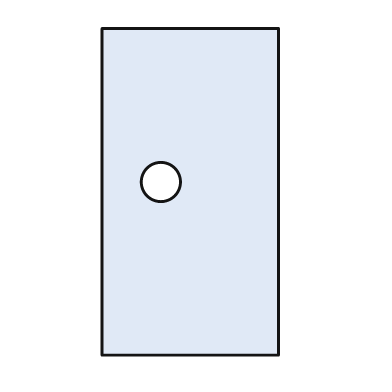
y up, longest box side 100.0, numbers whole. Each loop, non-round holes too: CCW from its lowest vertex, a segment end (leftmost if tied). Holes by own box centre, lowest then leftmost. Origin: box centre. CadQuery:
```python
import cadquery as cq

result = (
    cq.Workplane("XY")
    .moveTo(-27.0, -50.0)
    .lineTo(27.0, -50.0)
    .lineTo(27.0, 50.0)
    .lineTo(-27.0, 50.0)
    .close()
    .moveTo(-9.0, 3.0)
    .circle(6.0)
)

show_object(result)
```